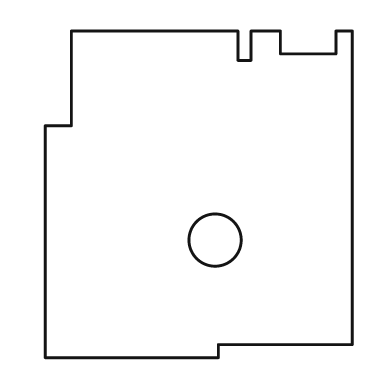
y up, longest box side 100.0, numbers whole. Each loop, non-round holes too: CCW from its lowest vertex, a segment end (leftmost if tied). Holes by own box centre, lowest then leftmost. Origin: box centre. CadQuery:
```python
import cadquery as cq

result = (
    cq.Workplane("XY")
    .moveTo(-47.0, -50.0)
    .lineTo(6.0, -50.0)
    .lineTo(6.0, -46.0)
    .lineTo(47.0, -46.0)
    .lineTo(47.0, 50.0)
    .lineTo(42.0, 50.0)
    .lineTo(42.0, 43.0)
    .lineTo(25.0, 43.0)
    .lineTo(25.0, 50.0)
    .lineTo(16.0, 50.0)
    .lineTo(16.0, 41.0)
    .lineTo(12.0, 41.0)
    .lineTo(12.0, 50.0)
    .lineTo(-39.0, 50.0)
    .lineTo(-39.0, 21.0)
    .lineTo(-47.0, 21.0)
    .close()
    .moveTo(5.0, -14.0)
    .circle(8.0)
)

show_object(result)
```